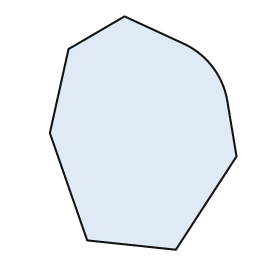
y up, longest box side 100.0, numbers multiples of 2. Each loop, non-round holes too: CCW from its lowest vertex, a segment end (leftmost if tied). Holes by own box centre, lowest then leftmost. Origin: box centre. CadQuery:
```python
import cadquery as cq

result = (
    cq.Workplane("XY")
    .moveTo(14.0, -50.0)
    .lineTo(40.0, -10.0)
    .lineTo(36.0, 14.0)
    .threePointArc((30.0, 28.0), (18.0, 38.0))
    .lineTo(-8.0, 50.0)
    .lineTo(-32.0, 36.0)
    .lineTo(-40.0, 0.0)
    .lineTo(-24.0, -46.0)
    .close()
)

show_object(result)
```